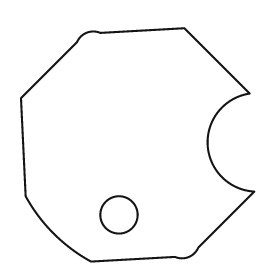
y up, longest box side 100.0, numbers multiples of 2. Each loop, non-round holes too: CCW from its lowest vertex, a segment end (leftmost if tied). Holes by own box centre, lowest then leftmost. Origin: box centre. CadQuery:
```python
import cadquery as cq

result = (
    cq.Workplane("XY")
    .moveTo(-20.0, -50.0)
    .lineTo(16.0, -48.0)
    .threePointArc((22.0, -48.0), (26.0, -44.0))
    .lineTo(50.0, -20.0)
    .threePointArc((30.0, 0.0), (48.0, 22.0))
    .lineTo(20.0, 50.0)
    .lineTo(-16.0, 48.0)
    .threePointArc((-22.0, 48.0), (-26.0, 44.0))
    .lineTo(-50.0, 20.0)
    .lineTo(-48.0, -22.0)
    .threePointArc((-36.0, -38.0), (-20.0, -50.0))
    .close()
    .moveTo(-8.0, -30.0)
    .circle(8.0)
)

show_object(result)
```